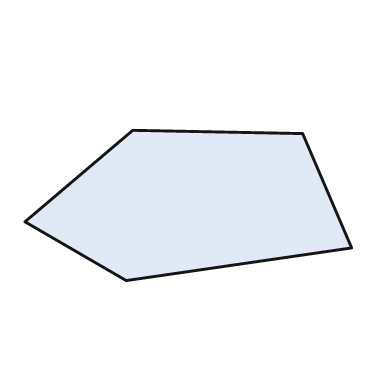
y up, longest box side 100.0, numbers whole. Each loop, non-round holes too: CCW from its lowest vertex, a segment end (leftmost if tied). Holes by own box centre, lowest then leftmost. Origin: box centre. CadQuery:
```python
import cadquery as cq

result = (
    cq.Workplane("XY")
    .moveTo(-19.0, -23.0)
    .lineTo(50.0, -13.0)
    .lineTo(35.0, 22.0)
    .lineTo(-17.0, 23.0)
    .lineTo(-50.0, -5.0)
    .close()
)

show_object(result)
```